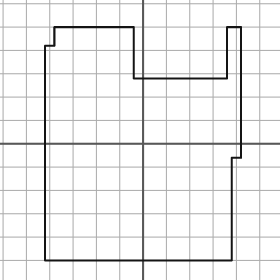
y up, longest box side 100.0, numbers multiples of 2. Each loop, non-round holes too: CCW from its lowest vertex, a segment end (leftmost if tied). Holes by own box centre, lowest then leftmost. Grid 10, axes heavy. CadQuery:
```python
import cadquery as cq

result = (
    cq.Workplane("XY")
    .moveTo(-42.0, -50.0)
    .lineTo(38.0, -50.0)
    .lineTo(38.0, -6.0)
    .lineTo(42.0, -6.0)
    .lineTo(42.0, 50.0)
    .lineTo(36.0, 50.0)
    .lineTo(36.0, 28.0)
    .lineTo(-4.0, 28.0)
    .lineTo(-4.0, 50.0)
    .lineTo(-38.0, 50.0)
    .lineTo(-38.0, 42.0)
    .lineTo(-42.0, 42.0)
    .close()
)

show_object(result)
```